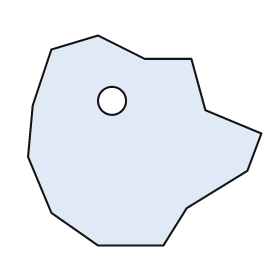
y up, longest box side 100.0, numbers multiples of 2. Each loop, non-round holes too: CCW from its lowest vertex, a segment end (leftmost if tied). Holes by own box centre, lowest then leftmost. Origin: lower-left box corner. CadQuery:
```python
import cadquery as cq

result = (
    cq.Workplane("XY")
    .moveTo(30.0, 0.0)
    .lineTo(58.0, 0.0)
    .lineTo(68.0, 16.0)
    .lineTo(94.0, 32.0)
    .lineTo(100.0, 48.0)
    .lineTo(76.0, 58.0)
    .lineTo(70.0, 80.0)
    .lineTo(50.0, 80.0)
    .lineTo(30.0, 90.0)
    .lineTo(10.0, 84.0)
    .lineTo(2.0, 60.0)
    .lineTo(0.0, 38.0)
    .lineTo(10.0, 14.0)
    .close()
    .moveTo(36.0, 62.0)
    .circle(6.0)
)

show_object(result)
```